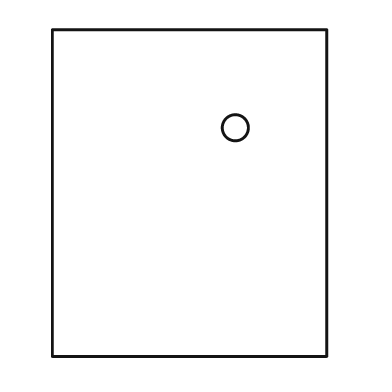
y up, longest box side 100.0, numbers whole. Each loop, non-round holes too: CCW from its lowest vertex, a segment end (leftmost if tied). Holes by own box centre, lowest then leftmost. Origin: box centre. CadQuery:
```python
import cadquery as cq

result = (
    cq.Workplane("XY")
    .moveTo(-42.0, -50.0)
    .lineTo(42.0, -50.0)
    .lineTo(42.0, 50.0)
    .lineTo(-42.0, 50.0)
    .close()
    .moveTo(14.0, 20.0)
    .circle(4.0)
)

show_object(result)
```